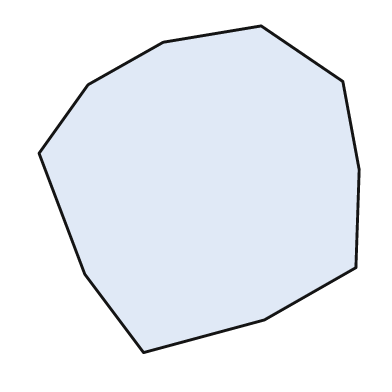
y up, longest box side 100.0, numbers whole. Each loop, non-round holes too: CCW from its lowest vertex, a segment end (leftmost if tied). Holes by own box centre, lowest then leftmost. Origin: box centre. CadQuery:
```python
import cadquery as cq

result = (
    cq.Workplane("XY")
    .moveTo(-17.0, -50.0)
    .lineTo(20.0, -40.0)
    .lineTo(48.0, -24.0)
    .lineTo(49.0, 6.0)
    .lineTo(44.0, 33.0)
    .lineTo(19.0, 50.0)
    .lineTo(-11.0, 45.0)
    .lineTo(-34.0, 32.0)
    .lineTo(-49.0, 11.0)
    .lineTo(-35.0, -26.0)
    .close()
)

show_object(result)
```